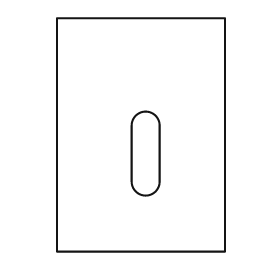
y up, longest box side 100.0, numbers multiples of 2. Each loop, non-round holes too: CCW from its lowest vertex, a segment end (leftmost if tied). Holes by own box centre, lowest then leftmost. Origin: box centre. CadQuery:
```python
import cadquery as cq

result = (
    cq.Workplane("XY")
    .moveTo(-36.0, -50.0)
    .lineTo(36.0, -50.0)
    .lineTo(36.0, 50.0)
    .lineTo(-36.0, 50.0)
    .close()
    .moveTo(-4.0, -20.0)
    .threePointArc((2.0, -26.0), (8.0, -20.0))
    .lineTo(8.0, 4.0)
    .threePointArc((2.0, 10.0), (-4.0, 4.0))
    .close()
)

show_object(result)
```